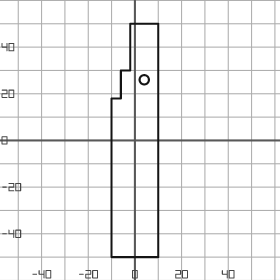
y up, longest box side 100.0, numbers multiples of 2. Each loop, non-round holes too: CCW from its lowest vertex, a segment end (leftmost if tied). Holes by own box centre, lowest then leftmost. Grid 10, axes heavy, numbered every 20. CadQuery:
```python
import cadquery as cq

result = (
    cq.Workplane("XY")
    .moveTo(-10.0, -50.0)
    .lineTo(10.0, -50.0)
    .lineTo(10.0, 50.0)
    .lineTo(-2.0, 50.0)
    .lineTo(-2.0, 30.0)
    .lineTo(-6.0, 30.0)
    .lineTo(-6.0, 18.0)
    .lineTo(-10.0, 18.0)
    .close()
    .moveTo(4.0, 26.0)
    .circle(2.0)
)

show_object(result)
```